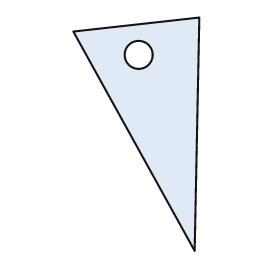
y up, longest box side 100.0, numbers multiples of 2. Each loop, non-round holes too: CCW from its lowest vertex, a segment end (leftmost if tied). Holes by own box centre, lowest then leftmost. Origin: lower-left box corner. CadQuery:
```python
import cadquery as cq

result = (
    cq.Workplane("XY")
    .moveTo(52.0, 0.0)
    .lineTo(54.0, 100.0)
    .lineTo(0.0, 94.0)
    .close()
    .moveTo(28.0, 84.0)
    .circle(6.0)
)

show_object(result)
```